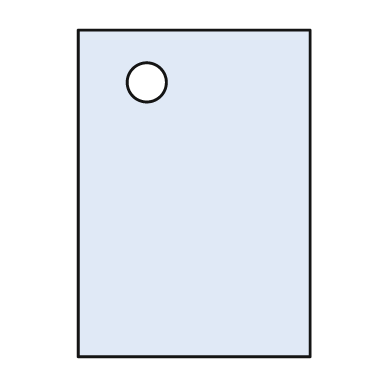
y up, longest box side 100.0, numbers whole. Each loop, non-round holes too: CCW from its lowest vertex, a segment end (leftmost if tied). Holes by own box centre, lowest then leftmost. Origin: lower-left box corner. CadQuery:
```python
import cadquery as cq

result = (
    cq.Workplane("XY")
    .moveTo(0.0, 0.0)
    .lineTo(71.0, 0.0)
    .lineTo(71.0, 100.0)
    .lineTo(0.0, 100.0)
    .close()
    .moveTo(21.0, 84.0)
    .circle(6.0)
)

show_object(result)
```